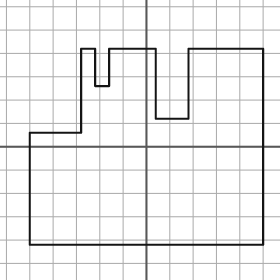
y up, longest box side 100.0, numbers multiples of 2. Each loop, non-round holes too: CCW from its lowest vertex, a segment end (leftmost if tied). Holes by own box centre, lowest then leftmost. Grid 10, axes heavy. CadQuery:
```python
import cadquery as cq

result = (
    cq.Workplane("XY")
    .moveTo(-50.0, -42.0)
    .lineTo(50.0, -42.0)
    .lineTo(50.0, 42.0)
    .lineTo(18.0, 42.0)
    .lineTo(18.0, 12.0)
    .lineTo(4.0, 12.0)
    .lineTo(4.0, 42.0)
    .lineTo(-16.0, 42.0)
    .lineTo(-16.0, 26.0)
    .lineTo(-22.0, 26.0)
    .lineTo(-22.0, 42.0)
    .lineTo(-28.0, 42.0)
    .lineTo(-28.0, 6.0)
    .lineTo(-50.0, 6.0)
    .close()
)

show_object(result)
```